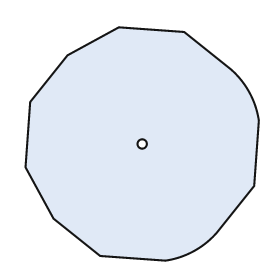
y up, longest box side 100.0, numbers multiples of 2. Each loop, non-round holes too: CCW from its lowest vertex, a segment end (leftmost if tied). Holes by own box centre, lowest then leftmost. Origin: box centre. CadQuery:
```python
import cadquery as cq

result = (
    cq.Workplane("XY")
    .moveTo(10.0, -50.0)
    .threePointArc((22.0, -46.0), (32.0, -38.0))
    .lineTo(48.0, -18.0)
    .lineTo(50.0, 10.0)
    .threePointArc((46.0, 22.0), (38.0, 32.0))
    .lineTo(18.0, 48.0)
    .lineTo(-10.0, 50.0)
    .lineTo(-32.0, 38.0)
    .lineTo(-48.0, 18.0)
    .lineTo(-50.0, -10.0)
    .lineTo(-38.0, -32.0)
    .lineTo(-18.0, -48.0)
    .close()
    .moveTo(0.0, 0.0)
    .circle(2.0)
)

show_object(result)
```